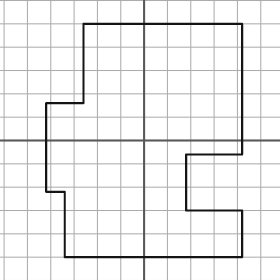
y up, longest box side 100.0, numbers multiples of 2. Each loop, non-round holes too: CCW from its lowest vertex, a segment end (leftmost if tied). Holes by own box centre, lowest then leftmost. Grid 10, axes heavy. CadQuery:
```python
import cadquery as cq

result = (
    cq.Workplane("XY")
    .moveTo(-34.0, -50.0)
    .lineTo(42.0, -50.0)
    .lineTo(42.0, -30.0)
    .lineTo(18.0, -30.0)
    .lineTo(18.0, -6.0)
    .lineTo(42.0, -6.0)
    .lineTo(42.0, 50.0)
    .lineTo(-26.0, 50.0)
    .lineTo(-26.0, 16.0)
    .lineTo(-42.0, 16.0)
    .lineTo(-42.0, -22.0)
    .lineTo(-34.0, -22.0)
    .close()
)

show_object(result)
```